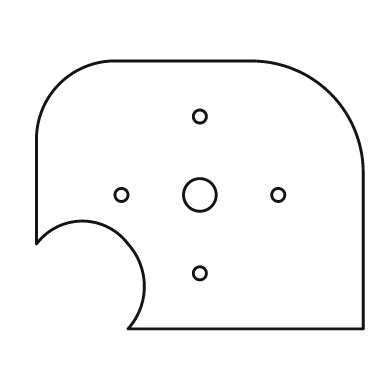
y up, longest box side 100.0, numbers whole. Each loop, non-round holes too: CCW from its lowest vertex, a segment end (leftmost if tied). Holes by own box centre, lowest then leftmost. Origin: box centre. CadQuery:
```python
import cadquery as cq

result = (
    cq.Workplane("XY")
    .moveTo(-22.0, -41.0)
    .lineTo(50.0, -41.0)
    .lineTo(50.0, 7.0)
    .threePointArc((40.0, 31.0), (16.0, 41.0))
    .lineTo(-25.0, 41.0)
    .threePointArc((-43.0, 34.0), (-50.0, 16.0))
    .lineTo(-50.0, -15.0)
    .threePointArc((-36.0, -8.0), (-22.0, -15.0))
    .threePointArc((-17.0, -28.0), (-22.0, -41.0))
    .close()
    .moveTo(0.0, -24.0)
    .circle(2.0)
    .moveTo(-24.0, 0.0)
    .circle(2.0)
    .moveTo(0.0, 0.0)
    .circle(5.0)
    .moveTo(24.0, 0.0)
    .circle(2.0)
    .moveTo(0.0, 24.0)
    .circle(2.0)
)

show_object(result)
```